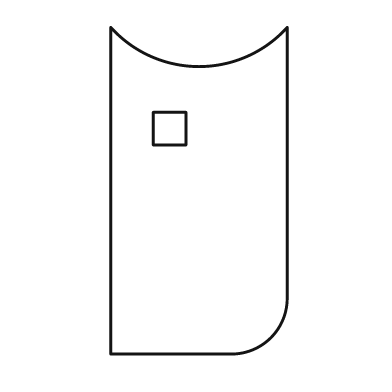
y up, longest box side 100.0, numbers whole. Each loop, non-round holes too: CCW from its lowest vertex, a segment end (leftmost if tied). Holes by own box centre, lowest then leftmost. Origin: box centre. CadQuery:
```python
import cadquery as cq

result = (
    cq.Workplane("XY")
    .moveTo(-27.0, -50.0)
    .lineTo(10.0, -50.0)
    .threePointArc((22.0, -45.0), (27.0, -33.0))
    .lineTo(27.0, 50.0)
    .threePointArc((0.0, 38.0), (-27.0, 50.0))
    .close()
    .moveTo(-14.0, 14.0)
    .lineTo(-4.0, 14.0)
    .lineTo(-4.0, 24.0)
    .lineTo(-14.0, 24.0)
    .close()
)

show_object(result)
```